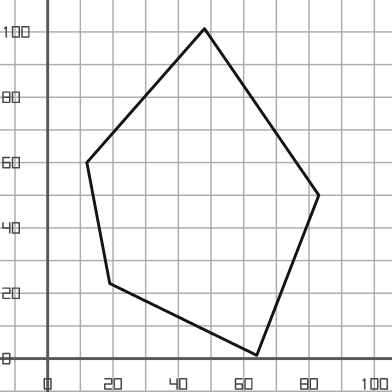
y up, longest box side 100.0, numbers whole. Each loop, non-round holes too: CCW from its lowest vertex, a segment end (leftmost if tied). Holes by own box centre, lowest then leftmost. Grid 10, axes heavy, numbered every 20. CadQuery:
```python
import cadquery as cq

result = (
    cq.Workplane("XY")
    .moveTo(64.0, 1.0)
    .lineTo(83.0, 50.0)
    .lineTo(48.0, 101.0)
    .lineTo(12.0, 60.0)
    .lineTo(19.0, 23.0)
    .close()
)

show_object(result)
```